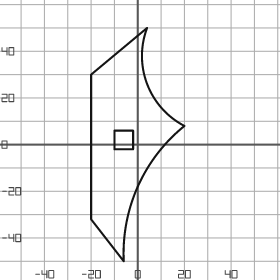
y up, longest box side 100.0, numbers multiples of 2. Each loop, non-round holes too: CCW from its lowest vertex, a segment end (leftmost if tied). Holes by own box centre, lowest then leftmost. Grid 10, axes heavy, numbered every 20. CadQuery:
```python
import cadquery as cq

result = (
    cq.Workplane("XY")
    .moveTo(-6.0, -50.0)
    .threePointArc((0.0, -18.0), (20.0, 8.0))
    .threePointArc((4.0, 26.0), (4.0, 50.0))
    .lineTo(-20.0, 30.0)
    .lineTo(-20.0, -32.0)
    .close()
    .moveTo(-10.0, -2.0)
    .lineTo(-2.0, -2.0)
    .lineTo(-2.0, 6.0)
    .lineTo(-10.0, 6.0)
    .close()
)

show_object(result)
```